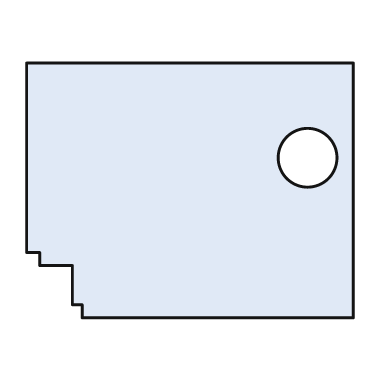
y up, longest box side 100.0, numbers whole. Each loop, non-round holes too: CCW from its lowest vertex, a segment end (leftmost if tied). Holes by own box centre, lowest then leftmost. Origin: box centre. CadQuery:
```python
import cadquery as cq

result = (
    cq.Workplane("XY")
    .moveTo(-33.0, -39.0)
    .lineTo(50.0, -39.0)
    .lineTo(50.0, 39.0)
    .lineTo(-50.0, 39.0)
    .lineTo(-50.0, -19.0)
    .lineTo(-46.0, -19.0)
    .lineTo(-46.0, -23.0)
    .lineTo(-36.0, -23.0)
    .lineTo(-36.0, -35.0)
    .lineTo(-33.0, -35.0)
    .close()
    .moveTo(36.0, 10.0)
    .circle(9.0)
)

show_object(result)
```